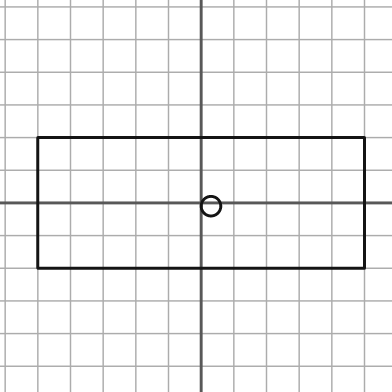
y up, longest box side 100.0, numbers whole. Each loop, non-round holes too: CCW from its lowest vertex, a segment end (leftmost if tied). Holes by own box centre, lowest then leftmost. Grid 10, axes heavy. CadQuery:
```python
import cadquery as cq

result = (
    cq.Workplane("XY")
    .moveTo(-50.0, -20.0)
    .lineTo(50.0, -20.0)
    .lineTo(50.0, 20.0)
    .lineTo(-50.0, 20.0)
    .close()
    .moveTo(3.0, -1.0)
    .circle(3.0)
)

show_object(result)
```